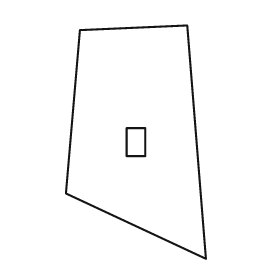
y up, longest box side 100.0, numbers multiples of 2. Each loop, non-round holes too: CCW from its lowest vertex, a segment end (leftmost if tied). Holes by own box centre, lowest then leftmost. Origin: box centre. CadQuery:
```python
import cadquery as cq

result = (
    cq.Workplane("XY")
    .moveTo(30.0, -50.0)
    .lineTo(22.0, 50.0)
    .lineTo(-24.0, 48.0)
    .lineTo(-30.0, -22.0)
    .close()
    .moveTo(-4.0, -6.0)
    .lineTo(4.0, -6.0)
    .lineTo(4.0, 6.0)
    .lineTo(-4.0, 6.0)
    .close()
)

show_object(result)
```